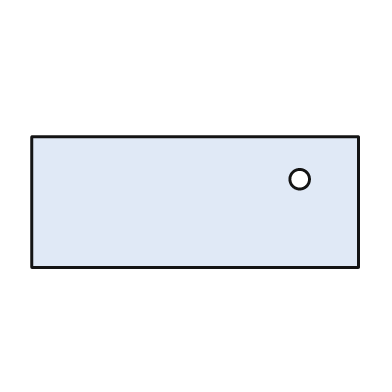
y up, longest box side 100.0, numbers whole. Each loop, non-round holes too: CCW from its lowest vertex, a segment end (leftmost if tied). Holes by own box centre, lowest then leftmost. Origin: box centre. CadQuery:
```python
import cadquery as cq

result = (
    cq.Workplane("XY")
    .moveTo(-50.0, -20.0)
    .lineTo(50.0, -20.0)
    .lineTo(50.0, 20.0)
    .lineTo(-50.0, 20.0)
    .close()
    .moveTo(32.0, 7.0)
    .circle(3.0)
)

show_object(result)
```